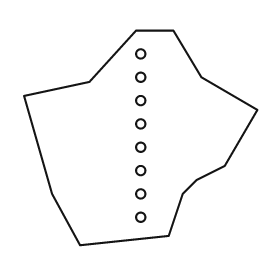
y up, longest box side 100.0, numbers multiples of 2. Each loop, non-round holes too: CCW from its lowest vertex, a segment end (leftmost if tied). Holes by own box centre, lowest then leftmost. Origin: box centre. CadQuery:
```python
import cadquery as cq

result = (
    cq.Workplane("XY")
    .moveTo(-26.0, -46.0)
    .lineTo(12.0, -42.0)
    .lineTo(18.0, -24.0)
    .lineTo(24.0, -18.0)
    .lineTo(36.0, -12.0)
    .lineTo(50.0, 12.0)
    .lineTo(26.0, 26.0)
    .lineTo(14.0, 46.0)
    .lineTo(-2.0, 46.0)
    .lineTo(-22.0, 24.0)
    .lineTo(-50.0, 18.0)
    .lineTo(-38.0, -24.0)
    .close()
    .moveTo(0.0, -34.0)
    .circle(2.0)
    .moveTo(0.0, -24.0)
    .circle(2.0)
    .moveTo(0.0, -14.0)
    .circle(2.0)
    .moveTo(0.0, -4.0)
    .circle(2.0)
    .moveTo(0.0, 6.0)
    .circle(2.0)
    .moveTo(0.0, 16.0)
    .circle(2.0)
    .moveTo(0.0, 26.0)
    .circle(2.0)
    .moveTo(0.0, 36.0)
    .circle(2.0)
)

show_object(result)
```